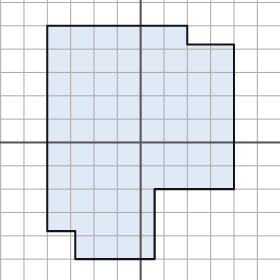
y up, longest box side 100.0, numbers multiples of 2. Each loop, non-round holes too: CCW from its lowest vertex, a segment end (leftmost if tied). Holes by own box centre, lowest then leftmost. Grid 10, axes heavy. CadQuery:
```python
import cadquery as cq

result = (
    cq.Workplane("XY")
    .moveTo(-28.0, -50.0)
    .lineTo(6.0, -50.0)
    .lineTo(6.0, -20.0)
    .lineTo(40.0, -20.0)
    .lineTo(40.0, 42.0)
    .lineTo(20.0, 42.0)
    .lineTo(20.0, 50.0)
    .lineTo(-40.0, 50.0)
    .lineTo(-40.0, -38.0)
    .lineTo(-28.0, -38.0)
    .close()
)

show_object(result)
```